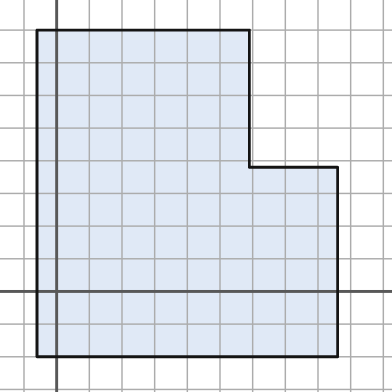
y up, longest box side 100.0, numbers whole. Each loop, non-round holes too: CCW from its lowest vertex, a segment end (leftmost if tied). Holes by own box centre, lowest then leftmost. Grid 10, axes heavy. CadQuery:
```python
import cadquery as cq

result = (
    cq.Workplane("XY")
    .moveTo(-6.0, -20.0)
    .lineTo(86.0, -20.0)
    .lineTo(86.0, 38.0)
    .lineTo(59.0, 38.0)
    .lineTo(59.0, 80.0)
    .lineTo(-6.0, 80.0)
    .close()
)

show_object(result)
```